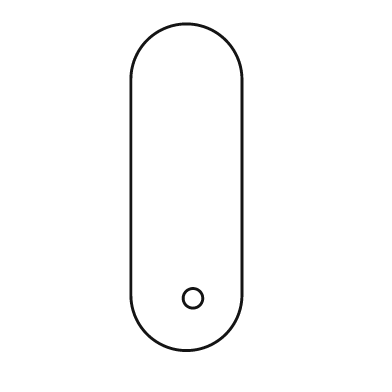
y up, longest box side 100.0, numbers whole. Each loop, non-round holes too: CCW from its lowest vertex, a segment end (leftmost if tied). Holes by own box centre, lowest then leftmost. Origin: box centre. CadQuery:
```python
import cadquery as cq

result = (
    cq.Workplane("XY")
    .moveTo(-17.0, -33.0)
    .threePointArc((0.0, -50.0), (17.0, -33.0))
    .lineTo(17.0, 33.0)
    .threePointArc((0.0, 50.0), (-17.0, 33.0))
    .close()
    .moveTo(2.0, -34.0)
    .circle(3.0)
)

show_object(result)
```